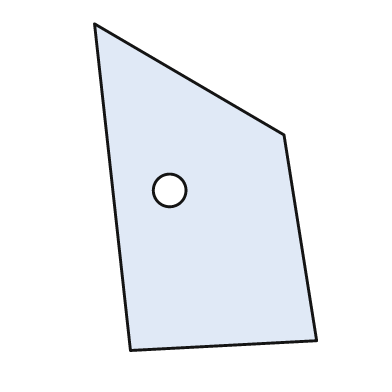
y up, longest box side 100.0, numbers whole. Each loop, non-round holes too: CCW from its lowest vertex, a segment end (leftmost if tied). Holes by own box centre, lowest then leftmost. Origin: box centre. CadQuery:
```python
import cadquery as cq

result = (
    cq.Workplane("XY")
    .moveTo(-23.0, -50.0)
    .lineTo(34.0, -47.0)
    .lineTo(24.0, 16.0)
    .lineTo(-34.0, 50.0)
    .close()
    .moveTo(-11.0, -1.0)
    .circle(5.0)
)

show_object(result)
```